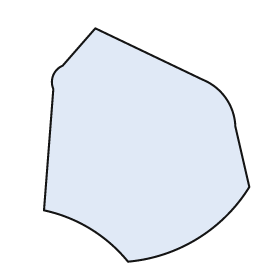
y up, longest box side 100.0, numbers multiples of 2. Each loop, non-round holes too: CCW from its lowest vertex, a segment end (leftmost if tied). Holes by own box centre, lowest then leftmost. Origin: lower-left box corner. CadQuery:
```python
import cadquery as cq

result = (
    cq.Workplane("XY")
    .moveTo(36.0, 0.0)
    .threePointArc((66.0, 10.0), (88.0, 32.0))
    .lineTo(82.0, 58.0)
    .threePointArc((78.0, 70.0), (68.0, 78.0))
    .lineTo(22.0, 100.0)
    .lineTo(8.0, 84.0)
    .threePointArc((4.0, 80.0), (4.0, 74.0))
    .lineTo(0.0, 22.0)
    .threePointArc((20.0, 14.0), (36.0, 0.0))
    .close()
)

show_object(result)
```